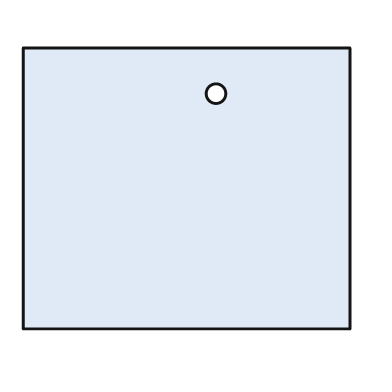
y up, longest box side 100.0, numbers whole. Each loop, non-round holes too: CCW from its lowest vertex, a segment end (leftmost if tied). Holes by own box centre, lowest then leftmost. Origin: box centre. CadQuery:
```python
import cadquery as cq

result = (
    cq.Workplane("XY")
    .moveTo(-50.0, -43.0)
    .lineTo(50.0, -43.0)
    .lineTo(50.0, 43.0)
    .lineTo(-50.0, 43.0)
    .close()
    .moveTo(9.0, 29.0)
    .circle(3.0)
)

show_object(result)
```